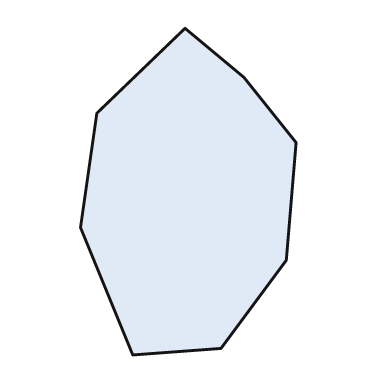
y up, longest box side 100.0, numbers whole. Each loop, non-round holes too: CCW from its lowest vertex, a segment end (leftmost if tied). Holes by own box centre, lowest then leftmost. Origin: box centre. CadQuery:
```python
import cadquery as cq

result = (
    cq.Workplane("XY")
    .moveTo(-17.0, -50.0)
    .lineTo(10.0, -48.0)
    .lineTo(30.0, -21.0)
    .lineTo(33.0, 15.0)
    .lineTo(17.0, 35.0)
    .lineTo(-1.0, 50.0)
    .lineTo(-28.0, 24.0)
    .lineTo(-33.0, -11.0)
    .close()
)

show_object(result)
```